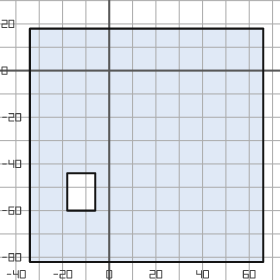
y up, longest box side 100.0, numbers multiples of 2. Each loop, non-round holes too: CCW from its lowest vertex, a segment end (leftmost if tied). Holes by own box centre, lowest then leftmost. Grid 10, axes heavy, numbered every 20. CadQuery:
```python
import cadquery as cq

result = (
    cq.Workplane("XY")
    .moveTo(-34.0, -82.0)
    .lineTo(66.0, -82.0)
    .lineTo(66.0, 18.0)
    .lineTo(-34.0, 18.0)
    .close()
    .moveTo(-18.0, -60.0)
    .lineTo(-6.0, -60.0)
    .lineTo(-6.0, -44.0)
    .lineTo(-18.0, -44.0)
    .close()
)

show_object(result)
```